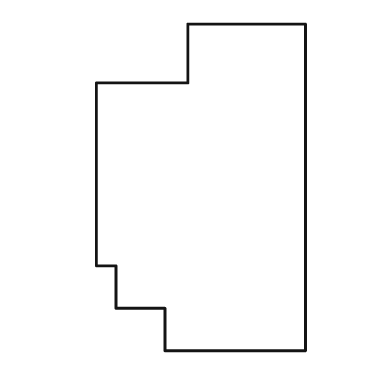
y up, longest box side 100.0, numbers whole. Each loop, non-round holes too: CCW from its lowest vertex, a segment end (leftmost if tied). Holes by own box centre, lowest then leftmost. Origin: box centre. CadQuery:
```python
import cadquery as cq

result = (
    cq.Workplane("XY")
    .moveTo(-11.0, -50.0)
    .lineTo(32.0, -50.0)
    .lineTo(32.0, 50.0)
    .lineTo(-4.0, 50.0)
    .lineTo(-4.0, 32.0)
    .lineTo(-32.0, 32.0)
    .lineTo(-32.0, -24.0)
    .lineTo(-26.0, -24.0)
    .lineTo(-26.0, -37.0)
    .lineTo(-11.0, -37.0)
    .close()
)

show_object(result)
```